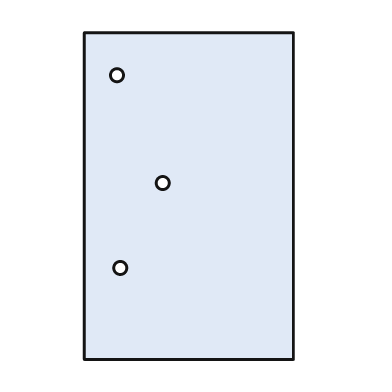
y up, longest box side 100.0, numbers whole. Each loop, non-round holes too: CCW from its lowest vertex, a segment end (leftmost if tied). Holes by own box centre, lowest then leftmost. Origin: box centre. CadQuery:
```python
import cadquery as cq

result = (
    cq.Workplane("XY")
    .moveTo(-32.0, -50.0)
    .lineTo(32.0, -50.0)
    .lineTo(32.0, 50.0)
    .lineTo(-32.0, 50.0)
    .close()
    .moveTo(-21.0, -22.0)
    .circle(2.0)
    .moveTo(-8.0, 4.0)
    .circle(2.0)
    .moveTo(-22.0, 37.0)
    .circle(2.0)
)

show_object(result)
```